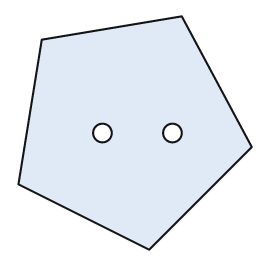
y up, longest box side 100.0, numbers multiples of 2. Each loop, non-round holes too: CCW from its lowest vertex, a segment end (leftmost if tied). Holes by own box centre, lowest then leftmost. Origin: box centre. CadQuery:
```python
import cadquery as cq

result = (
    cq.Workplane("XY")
    .moveTo(6.0, -50.0)
    .lineTo(50.0, -6.0)
    .lineTo(20.0, 50.0)
    .lineTo(-40.0, 40.0)
    .lineTo(-50.0, -22.0)
    .close()
    .moveTo(-14.0, 0.0)
    .circle(4.0)
    .moveTo(16.0, 0.0)
    .circle(4.0)
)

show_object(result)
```